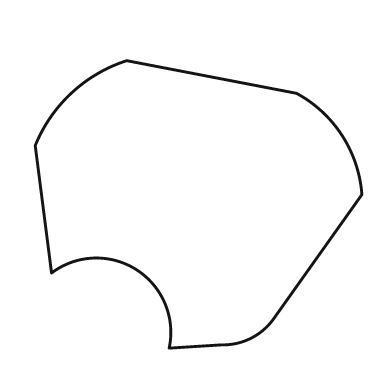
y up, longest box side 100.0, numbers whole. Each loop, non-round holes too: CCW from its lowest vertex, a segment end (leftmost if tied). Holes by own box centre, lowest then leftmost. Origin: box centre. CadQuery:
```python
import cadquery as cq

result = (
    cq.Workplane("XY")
    .moveTo(-9.0, -44.0)
    .lineTo(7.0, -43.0)
    .threePointArc((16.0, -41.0), (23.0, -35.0))
    .lineTo(50.0, 3.0)
    .threePointArc((44.0, 21.0), (30.0, 34.0))
    .lineTo(-22.0, 44.0)
    .threePointArc((-39.0, 34.0), (-50.0, 18.0))
    .lineTo(-45.0, -21.0)
    .threePointArc((-19.0, -20.0), (-9.0, -44.0))
    .close()
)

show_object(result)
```